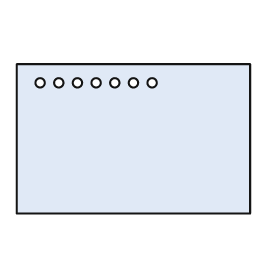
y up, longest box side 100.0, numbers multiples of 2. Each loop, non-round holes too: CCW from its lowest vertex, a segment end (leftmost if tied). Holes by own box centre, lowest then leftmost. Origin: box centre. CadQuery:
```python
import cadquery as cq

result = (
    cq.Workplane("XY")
    .moveTo(-50.0, -32.0)
    .lineTo(50.0, -32.0)
    .lineTo(50.0, 32.0)
    .lineTo(-50.0, 32.0)
    .close()
    .moveTo(-40.0, 24.0)
    .circle(2.0)
    .moveTo(-32.0, 24.0)
    .circle(2.0)
    .moveTo(-24.0, 24.0)
    .circle(2.0)
    .moveTo(-16.0, 24.0)
    .circle(2.0)
    .moveTo(-8.0, 24.0)
    .circle(2.0)
    .moveTo(0.0, 24.0)
    .circle(2.0)
    .moveTo(8.0, 24.0)
    .circle(2.0)
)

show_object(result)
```